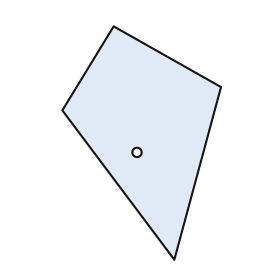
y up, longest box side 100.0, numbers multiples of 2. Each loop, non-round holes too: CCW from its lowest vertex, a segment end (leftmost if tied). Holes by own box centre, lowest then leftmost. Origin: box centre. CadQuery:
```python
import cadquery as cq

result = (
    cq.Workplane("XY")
    .moveTo(14.0, -50.0)
    .lineTo(34.0, 24.0)
    .lineTo(-12.0, 50.0)
    .lineTo(-34.0, 14.0)
    .close()
    .moveTo(-2.0, -4.0)
    .circle(2.0)
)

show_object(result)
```